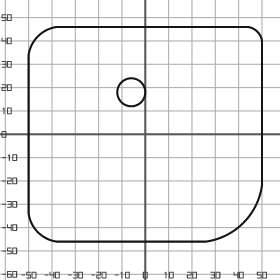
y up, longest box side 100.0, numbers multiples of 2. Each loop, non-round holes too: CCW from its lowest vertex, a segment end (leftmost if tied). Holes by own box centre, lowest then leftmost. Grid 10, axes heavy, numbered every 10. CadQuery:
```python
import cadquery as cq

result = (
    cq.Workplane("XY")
    .moveTo(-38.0, -46.0)
    .lineTo(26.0, -46.0)
    .threePointArc((42.0, -38.0), (50.0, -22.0))
    .lineTo(50.0, 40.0)
    .threePointArc((48.0, 44.0), (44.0, 46.0))
    .lineTo(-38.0, 46.0)
    .threePointArc((-46.0, 42.0), (-50.0, 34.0))
    .lineTo(-50.0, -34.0)
    .threePointArc((-46.0, -42.0), (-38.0, -46.0))
    .close()
    .moveTo(-6.0, 18.0)
    .circle(6.0)
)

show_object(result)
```